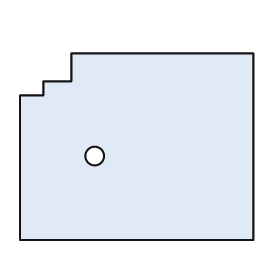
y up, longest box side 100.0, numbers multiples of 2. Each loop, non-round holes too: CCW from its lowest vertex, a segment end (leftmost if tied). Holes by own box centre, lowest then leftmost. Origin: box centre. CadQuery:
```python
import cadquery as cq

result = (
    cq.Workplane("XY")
    .moveTo(-50.0, -40.0)
    .lineTo(50.0, -40.0)
    .lineTo(50.0, 40.0)
    .lineTo(-28.0, 40.0)
    .lineTo(-28.0, 28.0)
    .lineTo(-40.0, 28.0)
    .lineTo(-40.0, 22.0)
    .lineTo(-50.0, 22.0)
    .close()
    .moveTo(-18.0, -4.0)
    .circle(4.0)
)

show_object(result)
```